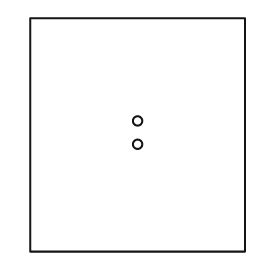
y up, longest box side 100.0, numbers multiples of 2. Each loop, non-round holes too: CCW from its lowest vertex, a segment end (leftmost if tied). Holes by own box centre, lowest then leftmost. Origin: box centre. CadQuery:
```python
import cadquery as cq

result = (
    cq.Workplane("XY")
    .moveTo(-46.0, -50.0)
    .lineTo(46.0, -50.0)
    .lineTo(46.0, 50.0)
    .lineTo(-46.0, 50.0)
    .close()
    .moveTo(0.0, -4.0)
    .circle(2.0)
    .moveTo(0.0, 6.0)
    .circle(2.0)
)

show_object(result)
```